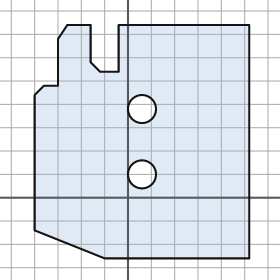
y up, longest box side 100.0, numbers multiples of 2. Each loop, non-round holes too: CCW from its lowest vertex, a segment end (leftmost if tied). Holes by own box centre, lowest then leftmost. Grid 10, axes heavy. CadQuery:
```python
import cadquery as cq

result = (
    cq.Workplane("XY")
    .moveTo(-10.0, -26.0)
    .lineTo(52.0, -26.0)
    .lineTo(52.0, 74.0)
    .lineTo(-4.0, 74.0)
    .lineTo(-4.0, 54.0)
    .lineTo(-12.0, 54.0)
    .lineTo(-16.0, 58.0)
    .lineTo(-16.0, 74.0)
    .lineTo(-26.0, 74.0)
    .lineTo(-30.0, 68.0)
    .lineTo(-30.0, 48.0)
    .lineTo(-36.0, 48.0)
    .lineTo(-40.0, 44.0)
    .lineTo(-40.0, -14.0)
    .close()
    .moveTo(6.0, 10.0)
    .circle(6.0)
    .moveTo(6.0, 38.0)
    .circle(6.0)
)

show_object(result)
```